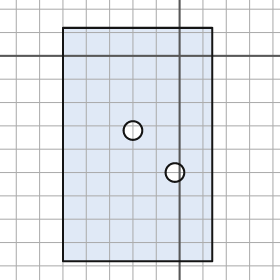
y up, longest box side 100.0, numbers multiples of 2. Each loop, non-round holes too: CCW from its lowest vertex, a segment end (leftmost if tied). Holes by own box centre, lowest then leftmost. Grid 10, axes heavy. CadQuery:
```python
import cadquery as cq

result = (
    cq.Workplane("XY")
    .moveTo(-50.0, -88.0)
    .lineTo(14.0, -88.0)
    .lineTo(14.0, 12.0)
    .lineTo(-50.0, 12.0)
    .close()
    .moveTo(-2.0, -50.0)
    .circle(4.0)
    .moveTo(-20.0, -32.0)
    .circle(4.0)
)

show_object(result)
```